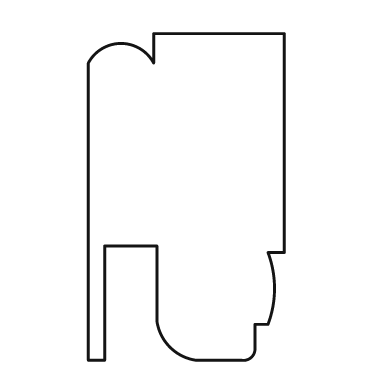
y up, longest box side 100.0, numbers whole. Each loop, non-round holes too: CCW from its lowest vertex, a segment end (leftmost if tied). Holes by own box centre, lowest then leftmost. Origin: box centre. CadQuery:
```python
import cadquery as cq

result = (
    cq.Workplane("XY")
    .moveTo(-30.0, -50.0)
    .lineTo(-25.0, -50.0)
    .lineTo(-25.0, -15.0)
    .lineTo(-9.0, -15.0)
    .lineTo(-9.0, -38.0)
    .threePointArc((-5.0, -46.0), (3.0, -50.0))
    .lineTo(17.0, -50.0)
    .threePointArc((20.0, -49.0), (21.0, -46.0))
    .lineTo(21.0, -39.0)
    .lineTo(25.0, -39.0)
    .threePointArc((27.0, -28.0), (25.0, -17.0))
    .lineTo(30.0, -17.0)
    .lineTo(30.0, 50.0)
    .lineTo(-10.0, 50.0)
    .lineTo(-10.0, 41.0)
    .threePointArc((-20.0, 47.0), (-30.0, 41.0))
    .close()
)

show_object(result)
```